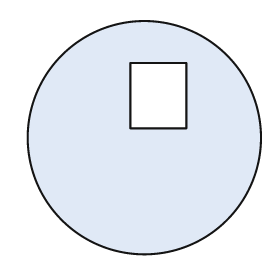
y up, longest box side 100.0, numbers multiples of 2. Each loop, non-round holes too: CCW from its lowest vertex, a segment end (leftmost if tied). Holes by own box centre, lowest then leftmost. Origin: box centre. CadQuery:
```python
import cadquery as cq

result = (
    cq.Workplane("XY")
    .moveTo(0.0, 0.0)
    .circle(50.0)
    .moveTo(-6.0, 4.0)
    .lineTo(18.0, 4.0)
    .lineTo(18.0, 32.0)
    .lineTo(-6.0, 32.0)
    .close()
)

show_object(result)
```